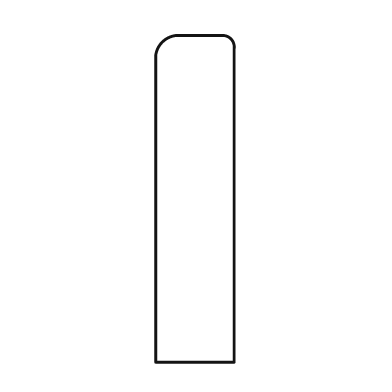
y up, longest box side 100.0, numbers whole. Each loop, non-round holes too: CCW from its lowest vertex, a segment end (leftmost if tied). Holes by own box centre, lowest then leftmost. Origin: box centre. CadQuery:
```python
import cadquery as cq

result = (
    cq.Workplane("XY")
    .moveTo(-12.0, -50.0)
    .lineTo(12.0, -50.0)
    .lineTo(12.0, 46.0)
    .threePointArc((11.0, 49.0), (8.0, 50.0))
    .lineTo(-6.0, 50.0)
    .threePointArc((-10.0, 48.0), (-12.0, 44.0))
    .close()
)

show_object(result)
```